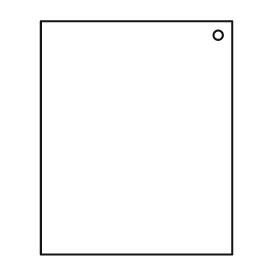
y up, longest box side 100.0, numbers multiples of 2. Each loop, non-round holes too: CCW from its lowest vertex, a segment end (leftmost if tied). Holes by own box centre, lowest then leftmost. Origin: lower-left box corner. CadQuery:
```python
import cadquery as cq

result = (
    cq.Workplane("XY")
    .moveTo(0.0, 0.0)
    .lineTo(82.0, 0.0)
    .lineTo(82.0, 100.0)
    .lineTo(0.0, 100.0)
    .close()
    .moveTo(76.0, 94.0)
    .circle(2.0)
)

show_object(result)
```